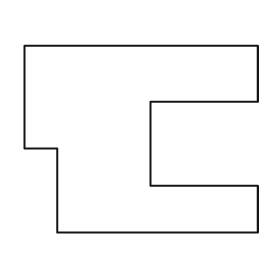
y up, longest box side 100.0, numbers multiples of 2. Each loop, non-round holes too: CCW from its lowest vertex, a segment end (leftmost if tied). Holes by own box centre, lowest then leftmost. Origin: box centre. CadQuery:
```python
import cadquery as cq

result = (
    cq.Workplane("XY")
    .moveTo(-36.0, -40.0)
    .lineTo(50.0, -40.0)
    .lineTo(50.0, -20.0)
    .lineTo(4.0, -20.0)
    .lineTo(4.0, 16.0)
    .lineTo(50.0, 16.0)
    .lineTo(50.0, 40.0)
    .lineTo(-50.0, 40.0)
    .lineTo(-50.0, -4.0)
    .lineTo(-36.0, -4.0)
    .close()
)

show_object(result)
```